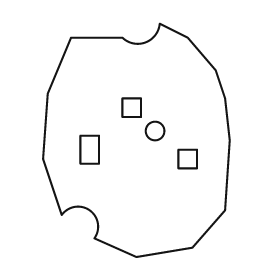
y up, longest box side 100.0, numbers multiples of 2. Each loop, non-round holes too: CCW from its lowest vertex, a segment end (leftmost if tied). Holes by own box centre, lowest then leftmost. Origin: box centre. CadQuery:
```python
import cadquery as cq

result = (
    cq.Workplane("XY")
    .moveTo(0.0, -50.0)
    .lineTo(24.0, -46.0)
    .lineTo(38.0, -30.0)
    .lineTo(40.0, 0.0)
    .lineTo(38.0, 18.0)
    .lineTo(34.0, 30.0)
    .lineTo(22.0, 44.0)
    .lineTo(10.0, 50.0)
    .threePointArc((4.0, 42.0), (-6.0, 44.0))
    .lineTo(-28.0, 44.0)
    .lineTo(-38.0, 20.0)
    .lineTo(-40.0, -8.0)
    .lineTo(-32.0, -32.0)
    .threePointArc((-20.0, -30.0), (-18.0, -42.0))
    .close()
    .moveTo(18.0, -12.0)
    .lineTo(26.0, -12.0)
    .lineTo(26.0, -4.0)
    .lineTo(18.0, -4.0)
    .close()
    .moveTo(-24.0, -10.0)
    .lineTo(-16.0, -10.0)
    .lineTo(-16.0, 2.0)
    .lineTo(-24.0, 2.0)
    .close()
    .moveTo(8.0, 4.0)
    .circle(4.0)
    .moveTo(-6.0, 10.0)
    .lineTo(2.0, 10.0)
    .lineTo(2.0, 18.0)
    .lineTo(-6.0, 18.0)
    .close()
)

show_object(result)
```